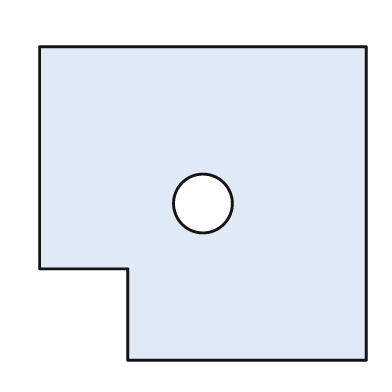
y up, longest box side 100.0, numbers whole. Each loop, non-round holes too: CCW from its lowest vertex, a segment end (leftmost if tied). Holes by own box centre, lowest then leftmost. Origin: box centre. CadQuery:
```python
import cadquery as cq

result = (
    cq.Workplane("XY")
    .moveTo(-23.0, -48.0)
    .lineTo(50.0, -48.0)
    .lineTo(50.0, 48.0)
    .lineTo(-50.0, 48.0)
    .lineTo(-50.0, -20.0)
    .lineTo(-23.0, -20.0)
    .close()
    .moveTo(0.0, 0.0)
    .circle(9.0)
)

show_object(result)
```